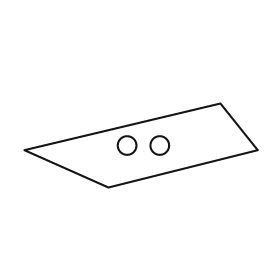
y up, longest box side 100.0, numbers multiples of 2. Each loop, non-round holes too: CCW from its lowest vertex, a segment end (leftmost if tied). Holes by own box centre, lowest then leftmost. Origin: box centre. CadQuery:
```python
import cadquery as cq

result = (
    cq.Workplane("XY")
    .moveTo(-14.0, -18.0)
    .lineTo(50.0, -2.0)
    .lineTo(34.0, 18.0)
    .lineTo(-50.0, -2.0)
    .close()
    .moveTo(-6.0, 0.0)
    .circle(4.0)
    .moveTo(8.0, 0.0)
    .circle(4.0)
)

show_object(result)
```